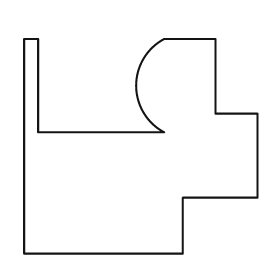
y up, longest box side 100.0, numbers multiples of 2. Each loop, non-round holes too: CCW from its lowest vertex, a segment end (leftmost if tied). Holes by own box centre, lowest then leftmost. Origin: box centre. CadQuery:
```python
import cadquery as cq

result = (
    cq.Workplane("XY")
    .moveTo(-50.0, -46.0)
    .lineTo(18.0, -46.0)
    .lineTo(18.0, -22.0)
    .lineTo(50.0, -22.0)
    .lineTo(50.0, 14.0)
    .lineTo(32.0, 14.0)
    .lineTo(32.0, 46.0)
    .lineTo(10.0, 46.0)
    .threePointArc((-2.0, 26.0), (10.0, 6.0))
    .lineTo(-44.0, 6.0)
    .lineTo(-44.0, 46.0)
    .lineTo(-50.0, 46.0)
    .close()
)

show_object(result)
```